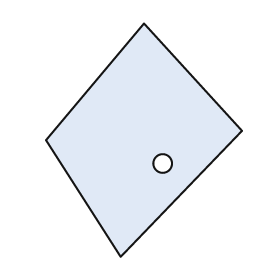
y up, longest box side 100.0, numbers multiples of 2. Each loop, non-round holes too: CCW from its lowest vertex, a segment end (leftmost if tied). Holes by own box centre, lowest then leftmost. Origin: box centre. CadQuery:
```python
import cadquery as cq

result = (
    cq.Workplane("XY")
    .moveTo(-10.0, -50.0)
    .lineTo(42.0, 4.0)
    .lineTo(0.0, 50.0)
    .lineTo(-42.0, 0.0)
    .close()
    .moveTo(8.0, -10.0)
    .circle(4.0)
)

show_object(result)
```